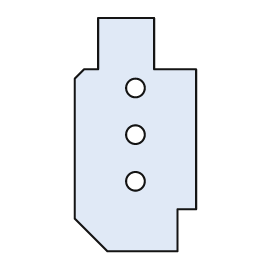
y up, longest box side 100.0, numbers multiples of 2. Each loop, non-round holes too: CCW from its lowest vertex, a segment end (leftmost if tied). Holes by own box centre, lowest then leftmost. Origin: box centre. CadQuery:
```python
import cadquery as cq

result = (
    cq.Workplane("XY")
    .moveTo(-12.0, -50.0)
    .lineTo(18.0, -50.0)
    .lineTo(18.0, -32.0)
    .lineTo(26.0, -32.0)
    .lineTo(26.0, 28.0)
    .lineTo(8.0, 28.0)
    .lineTo(8.0, 50.0)
    .lineTo(-16.0, 50.0)
    .lineTo(-16.0, 28.0)
    .lineTo(-22.0, 28.0)
    .lineTo(-26.0, 24.0)
    .lineTo(-26.0, -36.0)
    .close()
    .moveTo(0.0, -20.0)
    .circle(4.0)
    .moveTo(0.0, 0.0)
    .circle(4.0)
    .moveTo(0.0, 20.0)
    .circle(4.0)
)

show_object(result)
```